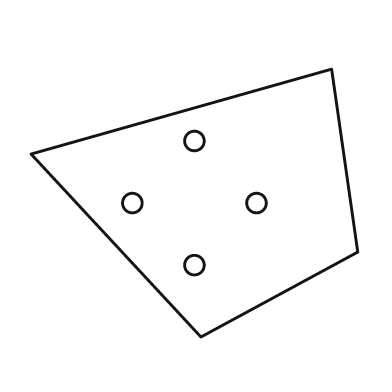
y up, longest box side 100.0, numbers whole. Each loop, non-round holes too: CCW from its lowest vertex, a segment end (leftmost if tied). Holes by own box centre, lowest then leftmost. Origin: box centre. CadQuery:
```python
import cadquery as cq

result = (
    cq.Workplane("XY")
    .moveTo(2.0, -41.0)
    .lineTo(50.0, -15.0)
    .lineTo(42.0, 41.0)
    .lineTo(-50.0, 15.0)
    .close()
    .moveTo(0.0, -19.0)
    .circle(3.0)
    .moveTo(-19.0, 0.0)
    .circle(3.0)
    .moveTo(19.0, 0.0)
    .circle(3.0)
    .moveTo(0.0, 19.0)
    .circle(3.0)
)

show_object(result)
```